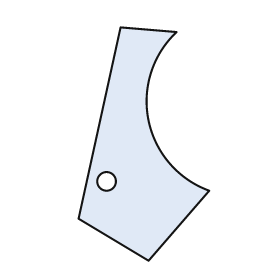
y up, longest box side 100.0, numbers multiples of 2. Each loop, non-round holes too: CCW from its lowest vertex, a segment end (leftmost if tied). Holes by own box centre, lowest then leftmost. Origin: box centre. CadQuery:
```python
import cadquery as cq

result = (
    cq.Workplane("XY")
    .moveTo(2.0, -50.0)
    .lineTo(28.0, -20.0)
    .threePointArc((2.0, 10.0), (14.0, 48.0))
    .lineTo(-10.0, 50.0)
    .lineTo(-28.0, -32.0)
    .close()
    .moveTo(-16.0, -16.0)
    .circle(4.0)
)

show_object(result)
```